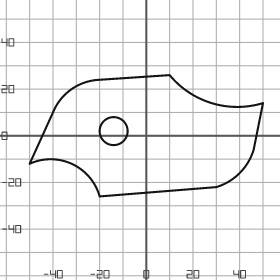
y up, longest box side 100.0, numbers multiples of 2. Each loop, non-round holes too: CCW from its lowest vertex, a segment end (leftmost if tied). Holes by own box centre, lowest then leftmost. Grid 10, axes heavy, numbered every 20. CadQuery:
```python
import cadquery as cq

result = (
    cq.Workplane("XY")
    .moveTo(-20.0, -26.0)
    .lineTo(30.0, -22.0)
    .threePointArc((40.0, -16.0), (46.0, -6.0))
    .lineTo(50.0, 14.0)
    .threePointArc((28.0, 14.0), (10.0, 26.0))
    .lineTo(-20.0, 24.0)
    .threePointArc((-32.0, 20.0), (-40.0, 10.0))
    .lineTo(-50.0, -12.0)
    .threePointArc((-32.0, -12.0), (-20.0, -26.0))
    .close()
    .moveTo(-14.0, 2.0)
    .circle(6.0)
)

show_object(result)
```